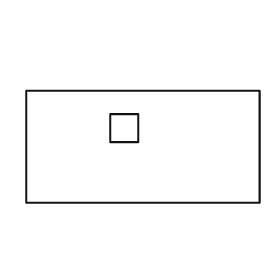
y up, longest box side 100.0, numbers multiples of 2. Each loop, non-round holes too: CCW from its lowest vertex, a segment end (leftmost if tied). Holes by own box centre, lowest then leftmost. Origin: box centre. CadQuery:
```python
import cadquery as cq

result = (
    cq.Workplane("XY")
    .moveTo(-50.0, -24.0)
    .lineTo(50.0, -24.0)
    .lineTo(50.0, 24.0)
    .lineTo(-50.0, 24.0)
    .close()
    .moveTo(-14.0, 2.0)
    .lineTo(-2.0, 2.0)
    .lineTo(-2.0, 14.0)
    .lineTo(-14.0, 14.0)
    .close()
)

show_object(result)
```